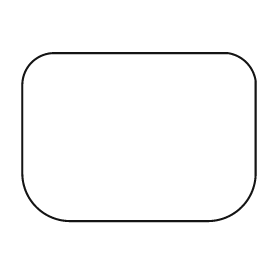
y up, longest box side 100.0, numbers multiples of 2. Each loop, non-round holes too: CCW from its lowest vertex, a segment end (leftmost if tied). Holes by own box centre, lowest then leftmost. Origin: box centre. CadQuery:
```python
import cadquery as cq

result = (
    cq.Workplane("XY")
    .moveTo(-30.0, -36.0)
    .lineTo(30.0, -36.0)
    .threePointArc((44.0, -30.0), (50.0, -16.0))
    .lineTo(50.0, 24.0)
    .threePointArc((46.0, 32.0), (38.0, 36.0))
    .lineTo(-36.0, 36.0)
    .threePointArc((-46.0, 32.0), (-50.0, 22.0))
    .lineTo(-50.0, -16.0)
    .threePointArc((-44.0, -30.0), (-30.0, -36.0))
    .close()
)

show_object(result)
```